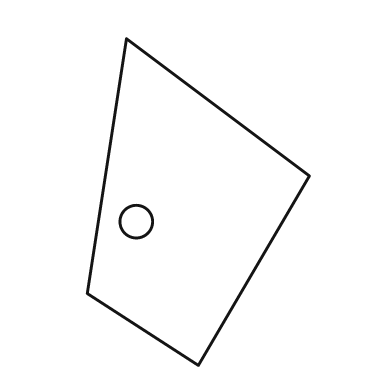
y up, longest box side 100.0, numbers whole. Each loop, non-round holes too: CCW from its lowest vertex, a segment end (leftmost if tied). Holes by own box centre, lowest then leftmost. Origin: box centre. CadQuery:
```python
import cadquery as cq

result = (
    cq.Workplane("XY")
    .moveTo(0.0, -50.0)
    .lineTo(34.0, 8.0)
    .lineTo(-22.0, 50.0)
    .lineTo(-34.0, -28.0)
    .close()
    .moveTo(-19.0, -6.0)
    .circle(5.0)
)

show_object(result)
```